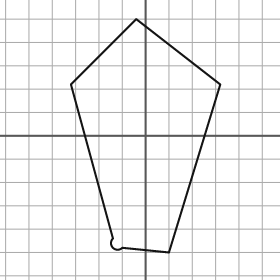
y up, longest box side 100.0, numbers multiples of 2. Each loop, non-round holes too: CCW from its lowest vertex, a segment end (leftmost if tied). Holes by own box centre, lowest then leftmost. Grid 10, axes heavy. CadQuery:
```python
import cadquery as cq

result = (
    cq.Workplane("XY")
    .moveTo(10.0, -50.0)
    .lineTo(32.0, 22.0)
    .lineTo(-4.0, 50.0)
    .lineTo(-32.0, 22.0)
    .lineTo(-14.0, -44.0)
    .threePointArc((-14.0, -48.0), (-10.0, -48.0))
    .close()
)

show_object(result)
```